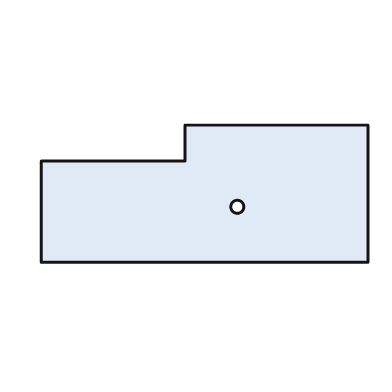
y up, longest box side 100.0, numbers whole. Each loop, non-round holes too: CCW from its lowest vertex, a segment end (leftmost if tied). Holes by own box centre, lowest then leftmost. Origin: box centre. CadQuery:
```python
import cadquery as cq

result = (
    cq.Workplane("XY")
    .moveTo(-50.0, -21.0)
    .lineTo(50.0, -21.0)
    .lineTo(50.0, 21.0)
    .lineTo(-6.0, 21.0)
    .lineTo(-6.0, 10.0)
    .lineTo(-50.0, 10.0)
    .close()
    .moveTo(10.0, -4.0)
    .circle(2.0)
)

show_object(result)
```